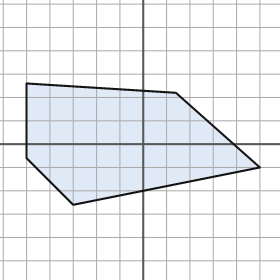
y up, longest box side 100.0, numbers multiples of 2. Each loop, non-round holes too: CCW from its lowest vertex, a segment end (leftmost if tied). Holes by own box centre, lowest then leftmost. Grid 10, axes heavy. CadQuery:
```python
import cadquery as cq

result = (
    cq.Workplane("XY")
    .moveTo(-30.0, -26.0)
    .lineTo(50.0, -10.0)
    .lineTo(14.0, 22.0)
    .lineTo(-50.0, 26.0)
    .lineTo(-50.0, -6.0)
    .close()
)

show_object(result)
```